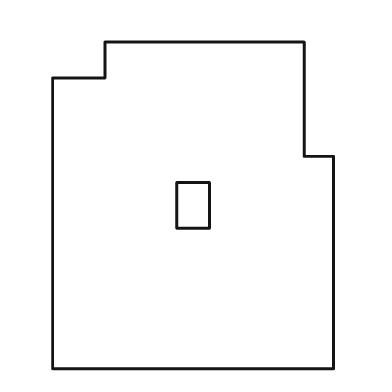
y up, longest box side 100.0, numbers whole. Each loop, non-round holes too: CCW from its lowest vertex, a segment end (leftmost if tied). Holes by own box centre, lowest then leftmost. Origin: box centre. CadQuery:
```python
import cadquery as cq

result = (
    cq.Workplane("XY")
    .moveTo(-43.0, -50.0)
    .lineTo(43.0, -50.0)
    .lineTo(43.0, 15.0)
    .lineTo(34.0, 15.0)
    .lineTo(34.0, 50.0)
    .lineTo(-27.0, 50.0)
    .lineTo(-27.0, 39.0)
    .lineTo(-43.0, 39.0)
    .close()
    .moveTo(-5.0, -7.0)
    .lineTo(5.0, -7.0)
    .lineTo(5.0, 7.0)
    .lineTo(-5.0, 7.0)
    .close()
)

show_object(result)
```